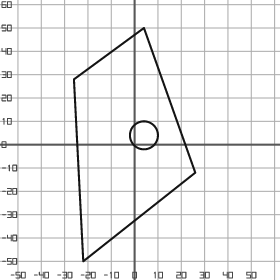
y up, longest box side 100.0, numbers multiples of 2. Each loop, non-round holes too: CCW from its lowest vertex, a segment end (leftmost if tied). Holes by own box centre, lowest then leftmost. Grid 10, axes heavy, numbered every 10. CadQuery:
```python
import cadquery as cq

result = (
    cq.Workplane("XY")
    .moveTo(-22.0, -50.0)
    .lineTo(26.0, -12.0)
    .lineTo(4.0, 50.0)
    .lineTo(-26.0, 28.0)
    .close()
    .moveTo(4.0, 4.0)
    .circle(6.0)
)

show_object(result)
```